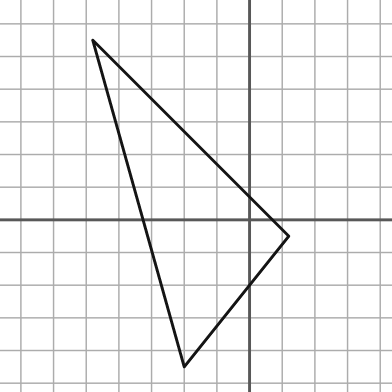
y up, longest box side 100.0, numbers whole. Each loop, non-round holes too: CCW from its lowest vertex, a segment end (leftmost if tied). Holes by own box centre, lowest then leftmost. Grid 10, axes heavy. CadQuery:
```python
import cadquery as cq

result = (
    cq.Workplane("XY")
    .moveTo(-20.0, -45.0)
    .lineTo(12.0, -5.0)
    .lineTo(-48.0, 55.0)
    .close()
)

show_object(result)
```